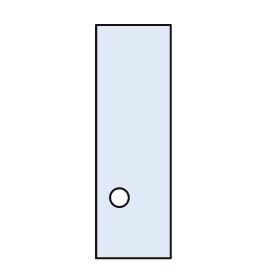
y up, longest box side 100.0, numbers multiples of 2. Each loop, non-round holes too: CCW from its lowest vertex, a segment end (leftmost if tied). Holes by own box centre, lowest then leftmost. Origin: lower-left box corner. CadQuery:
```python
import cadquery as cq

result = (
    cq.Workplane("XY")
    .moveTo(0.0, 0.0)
    .lineTo(32.0, 0.0)
    .lineTo(32.0, 100.0)
    .lineTo(0.0, 100.0)
    .close()
    .moveTo(10.0, 26.0)
    .circle(4.0)
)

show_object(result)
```